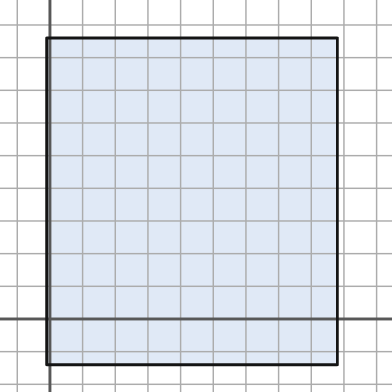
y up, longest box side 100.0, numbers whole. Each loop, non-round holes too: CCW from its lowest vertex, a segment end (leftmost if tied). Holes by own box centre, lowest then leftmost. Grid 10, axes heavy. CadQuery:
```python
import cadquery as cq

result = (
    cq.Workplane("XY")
    .moveTo(-1.0, -14.0)
    .lineTo(88.0, -14.0)
    .lineTo(88.0, 86.0)
    .lineTo(-1.0, 86.0)
    .close()
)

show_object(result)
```